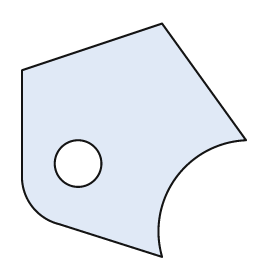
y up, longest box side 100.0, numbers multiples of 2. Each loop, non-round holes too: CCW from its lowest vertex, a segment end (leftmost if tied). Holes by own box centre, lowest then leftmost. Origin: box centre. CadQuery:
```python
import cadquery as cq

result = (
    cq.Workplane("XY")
    .moveTo(12.0, -50.0)
    .threePointArc((18.0, -16.0), (48.0, 0.0))
    .lineTo(12.0, 50.0)
    .lineTo(-48.0, 30.0)
    .lineTo(-48.0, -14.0)
    .threePointArc((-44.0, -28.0), (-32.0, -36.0))
    .close()
    .moveTo(-24.0, -10.0)
    .circle(10.0)
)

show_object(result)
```